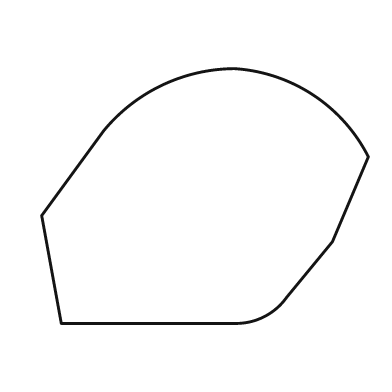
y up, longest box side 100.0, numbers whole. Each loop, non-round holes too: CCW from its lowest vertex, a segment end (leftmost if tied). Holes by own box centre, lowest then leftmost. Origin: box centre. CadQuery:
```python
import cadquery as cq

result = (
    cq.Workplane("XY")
    .moveTo(-44.0, -39.0)
    .lineTo(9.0, -39.0)
    .threePointArc((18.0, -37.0), (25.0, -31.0))
    .lineTo(39.0, -14.0)
    .lineTo(50.0, 12.0)
    .threePointArc((33.0, 31.0), (9.0, 39.0))
    .threePointArc((-13.0, 34.0), (-31.0, 20.0))
    .lineTo(-50.0, -6.0)
    .close()
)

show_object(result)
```